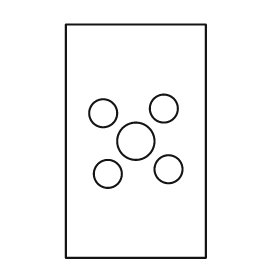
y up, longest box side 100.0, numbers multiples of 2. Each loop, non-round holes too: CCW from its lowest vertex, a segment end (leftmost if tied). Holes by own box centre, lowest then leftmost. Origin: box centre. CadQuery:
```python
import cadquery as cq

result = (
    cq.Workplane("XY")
    .moveTo(-30.0, -50.0)
    .lineTo(30.0, -50.0)
    .lineTo(30.0, 50.0)
    .lineTo(-30.0, 50.0)
    .close()
    .moveTo(-12.0, -14.0)
    .circle(6.0)
    .moveTo(14.0, -12.0)
    .circle(6.0)
    .moveTo(0.0, 0.0)
    .circle(8.0)
    .moveTo(-14.0, 12.0)
    .circle(6.0)
    .moveTo(12.0, 14.0)
    .circle(6.0)
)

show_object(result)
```